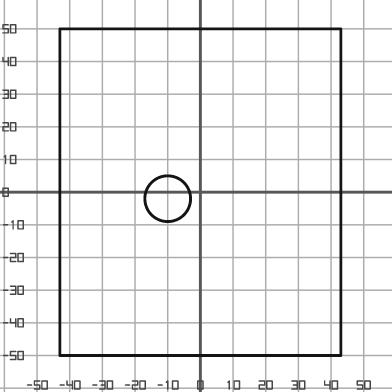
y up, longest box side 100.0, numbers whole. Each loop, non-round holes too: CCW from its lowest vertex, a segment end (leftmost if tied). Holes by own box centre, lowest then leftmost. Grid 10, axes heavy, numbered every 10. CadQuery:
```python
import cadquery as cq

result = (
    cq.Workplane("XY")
    .moveTo(-43.0, -50.0)
    .lineTo(43.0, -50.0)
    .lineTo(43.0, 50.0)
    .lineTo(-43.0, 50.0)
    .close()
    .moveTo(-10.0, -2.0)
    .circle(7.0)
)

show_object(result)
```